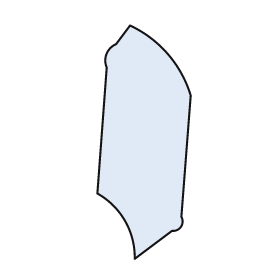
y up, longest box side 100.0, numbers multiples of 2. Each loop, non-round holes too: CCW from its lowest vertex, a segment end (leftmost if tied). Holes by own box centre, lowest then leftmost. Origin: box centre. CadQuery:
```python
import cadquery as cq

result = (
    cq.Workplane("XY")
    .moveTo(-4.0, -50.0)
    .lineTo(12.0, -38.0)
    .threePointArc((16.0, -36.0), (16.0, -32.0))
    .lineTo(20.0, 20.0)
    .threePointArc((10.0, 38.0), (-6.0, 50.0))
    .lineTo(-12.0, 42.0)
    .threePointArc((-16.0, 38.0), (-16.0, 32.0))
    .lineTo(-20.0, -22.0)
    .threePointArc((-8.0, -34.0), (-4.0, -50.0))
    .close()
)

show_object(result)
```